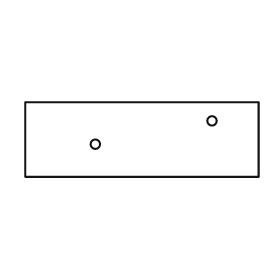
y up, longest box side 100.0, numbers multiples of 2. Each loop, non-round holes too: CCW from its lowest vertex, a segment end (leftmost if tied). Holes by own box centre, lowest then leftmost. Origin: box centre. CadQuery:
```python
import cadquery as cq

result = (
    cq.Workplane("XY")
    .moveTo(-50.0, -16.0)
    .lineTo(50.0, -16.0)
    .lineTo(50.0, 16.0)
    .lineTo(-50.0, 16.0)
    .close()
    .moveTo(-20.0, -2.0)
    .circle(2.0)
    .moveTo(30.0, 8.0)
    .circle(2.0)
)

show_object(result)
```